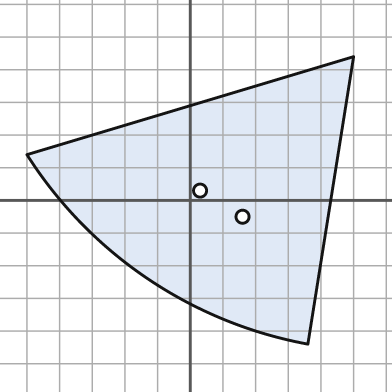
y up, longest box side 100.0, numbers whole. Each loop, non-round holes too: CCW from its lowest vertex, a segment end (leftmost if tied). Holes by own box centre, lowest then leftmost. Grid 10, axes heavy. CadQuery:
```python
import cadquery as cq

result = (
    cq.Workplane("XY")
    .moveTo(36.0, -44.0)
    .lineTo(50.0, 44.0)
    .lineTo(-50.0, 14.0)
    .threePointArc((-13.0, -24.0), (36.0, -44.0))
    .close()
    .moveTo(16.0, -5.0)
    .circle(2.0)
    .moveTo(3.0, 3.0)
    .circle(2.0)
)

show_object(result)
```